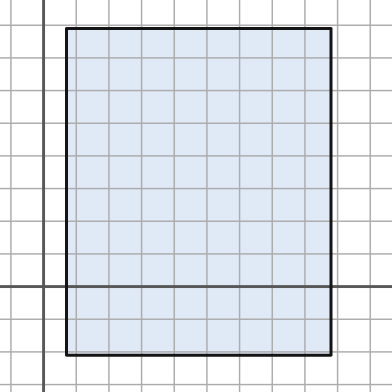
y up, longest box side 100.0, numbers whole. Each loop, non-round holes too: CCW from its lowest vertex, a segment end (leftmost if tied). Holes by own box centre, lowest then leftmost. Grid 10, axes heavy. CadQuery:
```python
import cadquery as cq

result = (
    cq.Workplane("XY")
    .moveTo(7.0, -21.0)
    .lineTo(88.0, -21.0)
    .lineTo(88.0, 79.0)
    .lineTo(7.0, 79.0)
    .close()
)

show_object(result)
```